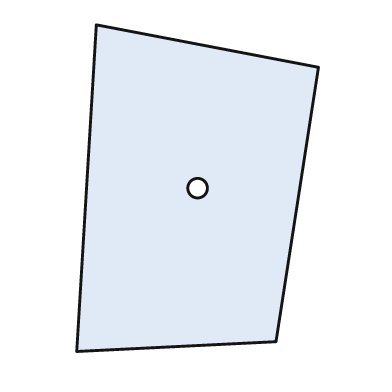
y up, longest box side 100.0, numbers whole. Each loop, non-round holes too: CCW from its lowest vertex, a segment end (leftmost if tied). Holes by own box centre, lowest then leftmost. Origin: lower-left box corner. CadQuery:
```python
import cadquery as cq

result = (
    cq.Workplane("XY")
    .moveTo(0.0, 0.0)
    .lineTo(61.0, 3.0)
    .lineTo(74.0, 87.0)
    .lineTo(6.0, 100.0)
    .close()
    .moveTo(37.0, 50.0)
    .circle(3.0)
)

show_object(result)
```